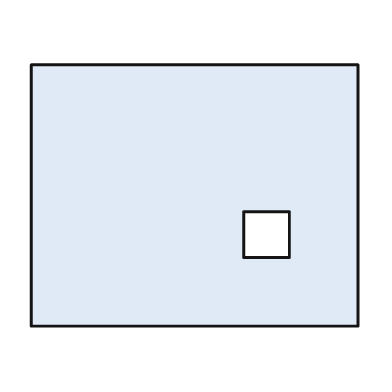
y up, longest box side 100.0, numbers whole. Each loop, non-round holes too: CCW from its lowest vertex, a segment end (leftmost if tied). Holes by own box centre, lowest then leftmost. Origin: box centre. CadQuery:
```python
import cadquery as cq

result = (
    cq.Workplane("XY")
    .moveTo(-50.0, -40.0)
    .lineTo(50.0, -40.0)
    .lineTo(50.0, 40.0)
    .lineTo(-50.0, 40.0)
    .close()
    .moveTo(15.0, -19.0)
    .lineTo(29.0, -19.0)
    .lineTo(29.0, -5.0)
    .lineTo(15.0, -5.0)
    .close()
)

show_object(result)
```